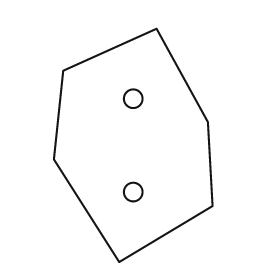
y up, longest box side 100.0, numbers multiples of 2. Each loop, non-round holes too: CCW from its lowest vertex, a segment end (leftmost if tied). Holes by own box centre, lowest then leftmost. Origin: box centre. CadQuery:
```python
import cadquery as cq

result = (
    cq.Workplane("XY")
    .moveTo(-6.0, -50.0)
    .lineTo(34.0, -26.0)
    .lineTo(32.0, 10.0)
    .lineTo(10.0, 50.0)
    .lineTo(-30.0, 32.0)
    .lineTo(-34.0, -6.0)
    .close()
    .moveTo(0.0, -20.0)
    .circle(4.0)
    .moveTo(0.0, 20.0)
    .circle(4.0)
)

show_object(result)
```